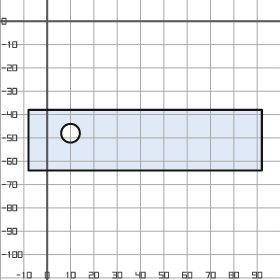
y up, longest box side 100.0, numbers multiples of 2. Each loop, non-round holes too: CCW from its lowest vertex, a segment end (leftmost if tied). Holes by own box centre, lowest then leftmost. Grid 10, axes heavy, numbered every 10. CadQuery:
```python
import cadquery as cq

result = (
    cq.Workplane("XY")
    .moveTo(-8.0, -64.0)
    .lineTo(92.0, -64.0)
    .lineTo(92.0, -38.0)
    .lineTo(-8.0, -38.0)
    .close()
    .moveTo(10.0, -48.0)
    .circle(4.0)
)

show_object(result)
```